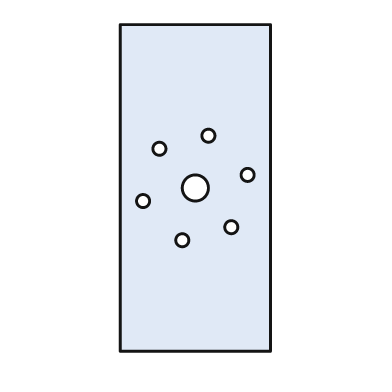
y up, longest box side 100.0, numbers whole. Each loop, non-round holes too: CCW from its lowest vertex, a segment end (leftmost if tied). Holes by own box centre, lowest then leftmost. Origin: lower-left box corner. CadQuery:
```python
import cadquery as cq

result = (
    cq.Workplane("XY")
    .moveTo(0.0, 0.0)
    .lineTo(46.0, 0.0)
    .lineTo(46.0, 100.0)
    .lineTo(0.0, 100.0)
    .close()
    .moveTo(19.0, 34.0)
    .circle(2.0)
    .moveTo(34.0, 38.0)
    .circle(2.0)
    .moveTo(7.0, 46.0)
    .circle(2.0)
    .moveTo(23.0, 50.0)
    .circle(4.0)
    .moveTo(39.0, 54.0)
    .circle(2.0)
    .moveTo(12.0, 62.0)
    .circle(2.0)
    .moveTo(27.0, 66.0)
    .circle(2.0)
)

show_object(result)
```